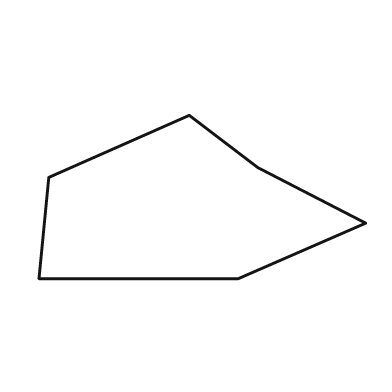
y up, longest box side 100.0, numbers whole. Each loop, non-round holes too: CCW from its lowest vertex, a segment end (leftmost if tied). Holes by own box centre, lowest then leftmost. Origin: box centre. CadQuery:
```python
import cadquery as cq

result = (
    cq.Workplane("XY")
    .moveTo(-50.0, -25.0)
    .lineTo(11.0, -25.0)
    .lineTo(50.0, -8.0)
    .lineTo(17.0, 9.0)
    .lineTo(-4.0, 25.0)
    .lineTo(-47.0, 6.0)
    .close()
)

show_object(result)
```